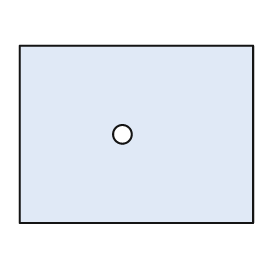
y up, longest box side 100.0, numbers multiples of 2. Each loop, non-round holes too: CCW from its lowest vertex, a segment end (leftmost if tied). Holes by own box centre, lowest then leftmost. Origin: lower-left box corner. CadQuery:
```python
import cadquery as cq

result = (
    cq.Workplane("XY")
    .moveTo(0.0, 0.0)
    .lineTo(100.0, 0.0)
    .lineTo(100.0, 76.0)
    .lineTo(0.0, 76.0)
    .close()
    .moveTo(44.0, 38.0)
    .circle(4.0)
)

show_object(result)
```